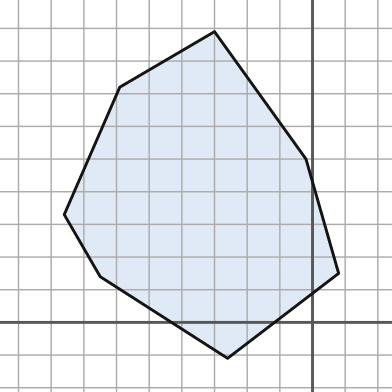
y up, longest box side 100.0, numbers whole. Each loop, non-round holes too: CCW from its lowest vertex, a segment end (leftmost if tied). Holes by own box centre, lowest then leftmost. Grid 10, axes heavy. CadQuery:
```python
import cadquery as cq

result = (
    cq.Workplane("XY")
    .moveTo(-26.0, -11.0)
    .lineTo(8.0, 15.0)
    .lineTo(-2.0, 50.0)
    .lineTo(-30.0, 89.0)
    .lineTo(-59.0, 72.0)
    .lineTo(-76.0, 33.0)
    .lineTo(-65.0, 14.0)
    .close()
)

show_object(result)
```